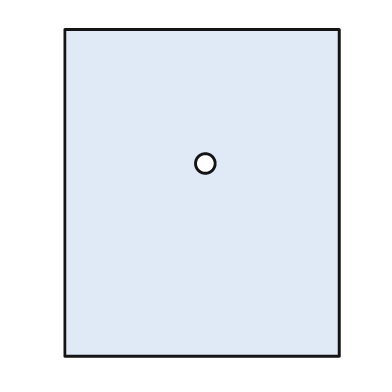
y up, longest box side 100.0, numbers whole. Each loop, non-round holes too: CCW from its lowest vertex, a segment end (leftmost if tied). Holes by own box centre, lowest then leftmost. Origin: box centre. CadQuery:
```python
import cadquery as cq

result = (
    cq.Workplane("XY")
    .moveTo(-42.0, -50.0)
    .lineTo(42.0, -50.0)
    .lineTo(42.0, 50.0)
    .lineTo(-42.0, 50.0)
    .close()
    .moveTo(1.0, 9.0)
    .circle(3.0)
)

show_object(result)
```